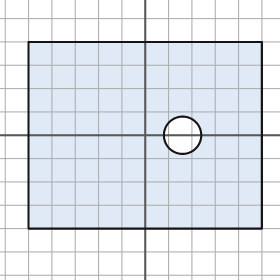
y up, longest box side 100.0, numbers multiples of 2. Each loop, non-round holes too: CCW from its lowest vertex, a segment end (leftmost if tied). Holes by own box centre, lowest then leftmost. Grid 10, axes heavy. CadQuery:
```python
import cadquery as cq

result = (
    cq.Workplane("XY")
    .moveTo(-50.0, -40.0)
    .lineTo(50.0, -40.0)
    .lineTo(50.0, 40.0)
    .lineTo(-50.0, 40.0)
    .close()
    .moveTo(16.0, 0.0)
    .circle(8.0)
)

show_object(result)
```